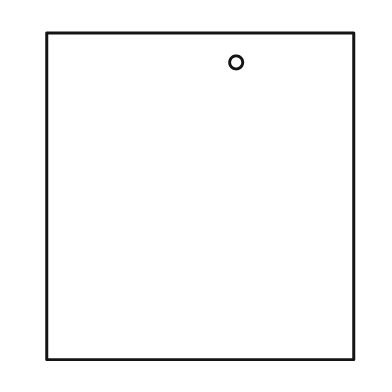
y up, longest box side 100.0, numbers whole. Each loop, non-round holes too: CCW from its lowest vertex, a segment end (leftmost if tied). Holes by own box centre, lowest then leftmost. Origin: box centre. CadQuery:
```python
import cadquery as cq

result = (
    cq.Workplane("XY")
    .moveTo(-47.0, -50.0)
    .lineTo(47.0, -50.0)
    .lineTo(47.0, 50.0)
    .lineTo(-47.0, 50.0)
    .close()
    .moveTo(11.0, 41.0)
    .circle(2.0)
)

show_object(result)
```